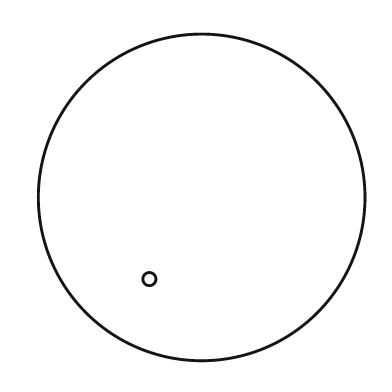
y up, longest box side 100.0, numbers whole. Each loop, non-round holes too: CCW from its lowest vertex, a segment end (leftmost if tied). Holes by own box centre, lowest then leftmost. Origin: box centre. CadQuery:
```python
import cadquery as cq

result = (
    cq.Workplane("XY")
    .moveTo(0.0, 0.0)
    .circle(50.0)
    .moveTo(-16.0, -25.0)
    .circle(2.0)
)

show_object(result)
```